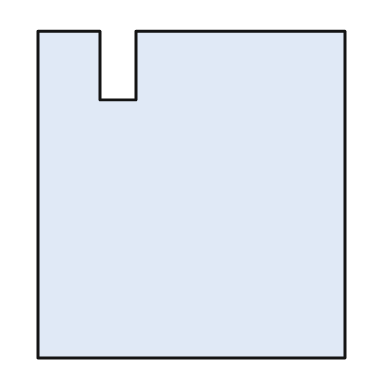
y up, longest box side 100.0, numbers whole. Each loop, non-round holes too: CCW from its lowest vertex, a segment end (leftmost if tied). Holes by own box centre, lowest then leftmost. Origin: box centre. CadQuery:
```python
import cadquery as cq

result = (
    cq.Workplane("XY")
    .moveTo(-47.0, -50.0)
    .lineTo(47.0, -50.0)
    .lineTo(47.0, 50.0)
    .lineTo(-17.0, 50.0)
    .lineTo(-17.0, 29.0)
    .lineTo(-28.0, 29.0)
    .lineTo(-28.0, 50.0)
    .lineTo(-47.0, 50.0)
    .close()
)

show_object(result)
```